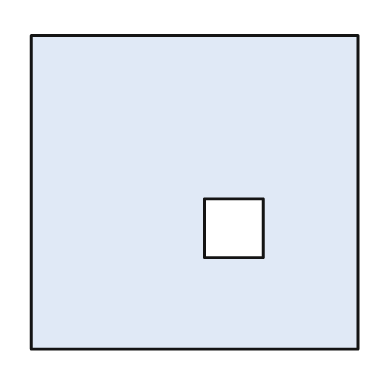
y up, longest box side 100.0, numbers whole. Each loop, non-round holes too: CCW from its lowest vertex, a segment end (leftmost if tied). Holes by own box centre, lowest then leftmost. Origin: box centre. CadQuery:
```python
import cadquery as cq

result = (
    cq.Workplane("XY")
    .moveTo(-50.0, -48.0)
    .lineTo(50.0, -48.0)
    .lineTo(50.0, 48.0)
    .lineTo(-50.0, 48.0)
    .close()
    .moveTo(3.0, -20.0)
    .lineTo(21.0, -20.0)
    .lineTo(21.0, -2.0)
    .lineTo(3.0, -2.0)
    .close()
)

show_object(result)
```